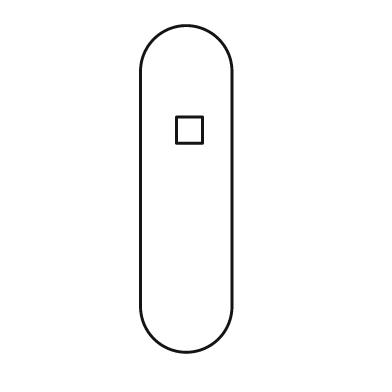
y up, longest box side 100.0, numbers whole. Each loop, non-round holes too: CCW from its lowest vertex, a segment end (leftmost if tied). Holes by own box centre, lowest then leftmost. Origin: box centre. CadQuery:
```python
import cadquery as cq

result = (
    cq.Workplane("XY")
    .moveTo(-14.0, -36.0)
    .threePointArc((0.0, -50.0), (14.0, -36.0))
    .lineTo(14.0, 36.0)
    .threePointArc((0.0, 50.0), (-14.0, 36.0))
    .close()
    .moveTo(-3.0, 14.0)
    .lineTo(5.0, 14.0)
    .lineTo(5.0, 22.0)
    .lineTo(-3.0, 22.0)
    .close()
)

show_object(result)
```